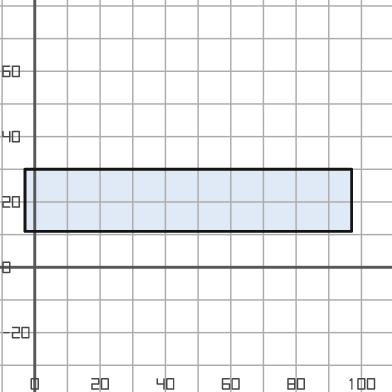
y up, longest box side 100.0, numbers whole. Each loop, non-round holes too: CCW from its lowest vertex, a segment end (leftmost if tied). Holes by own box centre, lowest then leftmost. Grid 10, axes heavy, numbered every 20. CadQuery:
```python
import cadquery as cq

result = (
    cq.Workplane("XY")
    .moveTo(-3.0, 11.0)
    .lineTo(97.0, 11.0)
    .lineTo(97.0, 30.0)
    .lineTo(-3.0, 30.0)
    .close()
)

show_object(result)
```